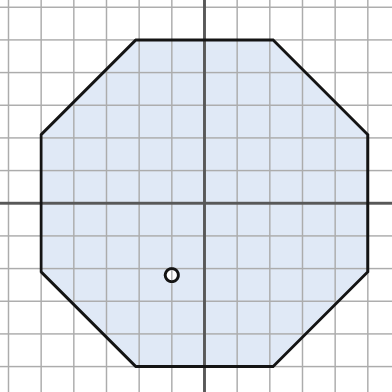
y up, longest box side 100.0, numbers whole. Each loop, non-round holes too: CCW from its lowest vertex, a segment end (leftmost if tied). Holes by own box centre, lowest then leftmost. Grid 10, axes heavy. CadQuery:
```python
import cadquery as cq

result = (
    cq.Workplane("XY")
    .moveTo(-21.0, -50.0)
    .lineTo(21.0, -50.0)
    .lineTo(50.0, -21.0)
    .lineTo(50.0, 21.0)
    .lineTo(21.0, 50.0)
    .lineTo(-21.0, 50.0)
    .lineTo(-50.0, 21.0)
    .lineTo(-50.0, -21.0)
    .close()
    .moveTo(-10.0, -22.0)
    .circle(2.0)
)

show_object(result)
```